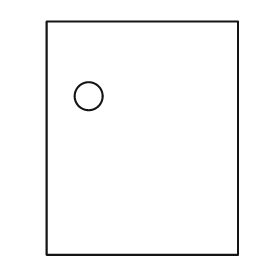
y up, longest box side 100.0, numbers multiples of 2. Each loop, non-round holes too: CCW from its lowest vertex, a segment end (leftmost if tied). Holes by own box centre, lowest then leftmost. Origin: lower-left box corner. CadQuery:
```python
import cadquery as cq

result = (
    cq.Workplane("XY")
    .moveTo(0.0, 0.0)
    .lineTo(82.0, 0.0)
    .lineTo(82.0, 100.0)
    .lineTo(0.0, 100.0)
    .close()
    .moveTo(18.0, 68.0)
    .circle(6.0)
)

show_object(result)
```